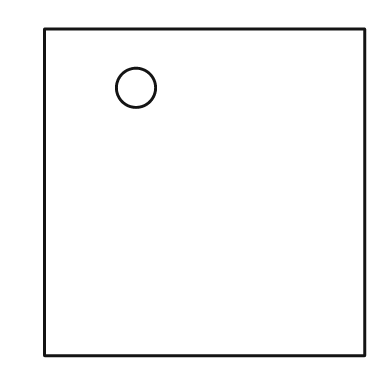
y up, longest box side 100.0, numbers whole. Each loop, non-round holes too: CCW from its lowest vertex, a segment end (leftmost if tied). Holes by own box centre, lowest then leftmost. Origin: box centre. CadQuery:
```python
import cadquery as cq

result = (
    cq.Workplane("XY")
    .moveTo(-49.0, -50.0)
    .lineTo(49.0, -50.0)
    .lineTo(49.0, 50.0)
    .lineTo(-49.0, 50.0)
    .close()
    .moveTo(-21.0, 32.0)
    .circle(6.0)
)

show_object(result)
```